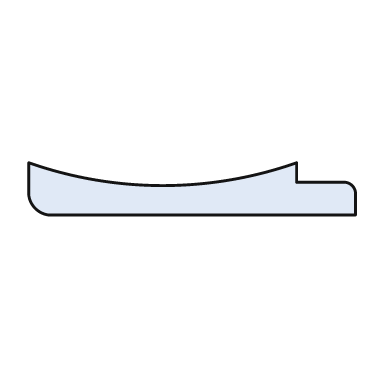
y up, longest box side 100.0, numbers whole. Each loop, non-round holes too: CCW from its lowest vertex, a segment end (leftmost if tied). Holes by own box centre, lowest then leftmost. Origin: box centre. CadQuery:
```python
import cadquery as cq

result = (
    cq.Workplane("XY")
    .moveTo(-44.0, -8.0)
    .lineTo(50.0, -8.0)
    .lineTo(50.0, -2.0)
    .threePointArc((49.0, 1.0), (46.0, 2.0))
    .lineTo(32.0, 2.0)
    .lineTo(32.0, 8.0)
    .threePointArc((-9.0, 1.0), (-50.0, 8.0))
    .lineTo(-50.0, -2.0)
    .threePointArc((-48.0, -6.0), (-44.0, -8.0))
    .close()
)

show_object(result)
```